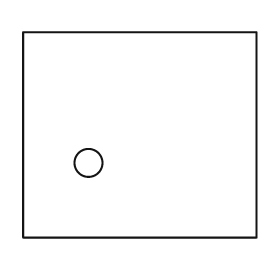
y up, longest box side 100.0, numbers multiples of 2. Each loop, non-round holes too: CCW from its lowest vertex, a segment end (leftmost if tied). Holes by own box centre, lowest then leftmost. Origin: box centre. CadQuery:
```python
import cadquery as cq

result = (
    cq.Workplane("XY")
    .moveTo(-50.0, -44.0)
    .lineTo(50.0, -44.0)
    .lineTo(50.0, 44.0)
    .lineTo(-50.0, 44.0)
    .close()
    .moveTo(-22.0, -12.0)
    .circle(6.0)
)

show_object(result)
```